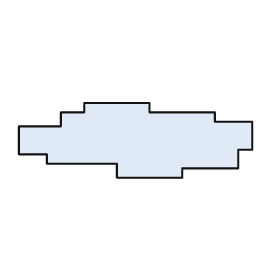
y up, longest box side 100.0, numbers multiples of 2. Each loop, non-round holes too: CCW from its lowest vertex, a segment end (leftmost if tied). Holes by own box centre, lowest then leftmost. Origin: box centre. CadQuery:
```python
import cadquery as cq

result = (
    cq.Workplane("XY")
    .moveTo(-8.0, -16.0)
    .lineTo(20.0, -16.0)
    .lineTo(20.0, -12.0)
    .lineTo(44.0, -12.0)
    .lineTo(44.0, -4.0)
    .lineTo(50.0, -4.0)
    .lineTo(50.0, 8.0)
    .lineTo(34.0, 8.0)
    .lineTo(34.0, 12.0)
    .lineTo(6.0, 12.0)
    .lineTo(6.0, 16.0)
    .lineTo(-22.0, 16.0)
    .lineTo(-22.0, 12.0)
    .lineTo(-32.0, 12.0)
    .lineTo(-32.0, 6.0)
    .lineTo(-50.0, 6.0)
    .lineTo(-50.0, -6.0)
    .lineTo(-38.0, -6.0)
    .lineTo(-38.0, -10.0)
    .lineTo(-8.0, -10.0)
    .close()
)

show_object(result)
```